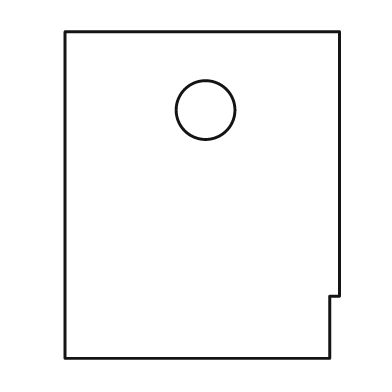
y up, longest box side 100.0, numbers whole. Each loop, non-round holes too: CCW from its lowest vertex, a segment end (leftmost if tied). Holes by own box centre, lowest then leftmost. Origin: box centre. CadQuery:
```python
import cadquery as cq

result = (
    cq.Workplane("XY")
    .moveTo(-42.0, -50.0)
    .lineTo(39.0, -50.0)
    .lineTo(39.0, -31.0)
    .lineTo(42.0, -31.0)
    .lineTo(42.0, 50.0)
    .lineTo(-42.0, 50.0)
    .close()
    .moveTo(1.0, 26.0)
    .circle(9.0)
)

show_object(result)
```